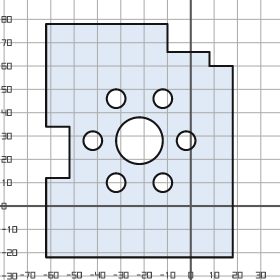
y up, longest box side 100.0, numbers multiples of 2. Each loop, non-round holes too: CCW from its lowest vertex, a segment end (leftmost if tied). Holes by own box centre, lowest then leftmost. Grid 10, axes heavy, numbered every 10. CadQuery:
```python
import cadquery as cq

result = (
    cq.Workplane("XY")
    .moveTo(-62.0, -22.0)
    .lineTo(18.0, -22.0)
    .lineTo(18.0, 60.0)
    .lineTo(8.0, 60.0)
    .lineTo(8.0, 66.0)
    .lineTo(-10.0, 66.0)
    .lineTo(-10.0, 78.0)
    .lineTo(-62.0, 78.0)
    .lineTo(-62.0, 34.0)
    .lineTo(-52.0, 34.0)
    .lineTo(-52.0, 12.0)
    .lineTo(-62.0, 12.0)
    .close()
    .moveTo(-32.0, 10.0)
    .circle(4.0)
    .moveTo(-12.0, 10.0)
    .circle(4.0)
    .moveTo(-42.0, 28.0)
    .circle(4.0)
    .moveTo(-22.0, 28.0)
    .circle(10.0)
    .moveTo(-2.0, 28.0)
    .circle(4.0)
    .moveTo(-32.0, 46.0)
    .circle(4.0)
    .moveTo(-12.0, 46.0)
    .circle(4.0)
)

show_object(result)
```